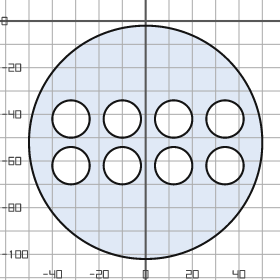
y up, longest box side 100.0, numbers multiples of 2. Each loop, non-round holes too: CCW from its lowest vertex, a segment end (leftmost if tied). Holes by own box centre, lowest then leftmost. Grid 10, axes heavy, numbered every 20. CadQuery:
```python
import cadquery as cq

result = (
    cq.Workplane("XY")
    .moveTo(0.0, -52.0)
    .circle(50.0)
    .moveTo(-32.0, -62.0)
    .circle(8.0)
    .moveTo(-10.0, -62.0)
    .circle(8.0)
    .moveTo(12.0, -62.0)
    .circle(8.0)
    .moveTo(34.0, -62.0)
    .circle(8.0)
    .moveTo(-32.0, -42.0)
    .circle(8.0)
    .moveTo(-10.0, -42.0)
    .circle(8.0)
    .moveTo(12.0, -42.0)
    .circle(8.0)
    .moveTo(34.0, -42.0)
    .circle(8.0)
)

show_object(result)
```